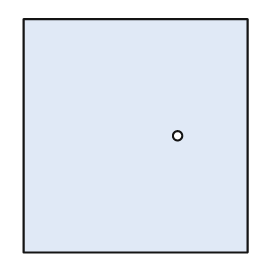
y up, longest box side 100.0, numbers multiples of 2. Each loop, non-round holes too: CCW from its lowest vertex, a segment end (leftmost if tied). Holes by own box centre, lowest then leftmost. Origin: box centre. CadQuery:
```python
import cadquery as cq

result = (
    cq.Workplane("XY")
    .moveTo(-48.0, -50.0)
    .lineTo(48.0, -50.0)
    .lineTo(48.0, 50.0)
    .lineTo(-48.0, 50.0)
    .close()
    .moveTo(18.0, 0.0)
    .circle(2.0)
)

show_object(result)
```